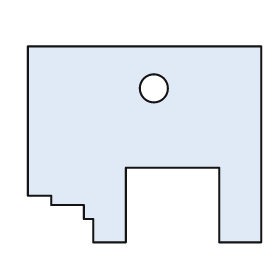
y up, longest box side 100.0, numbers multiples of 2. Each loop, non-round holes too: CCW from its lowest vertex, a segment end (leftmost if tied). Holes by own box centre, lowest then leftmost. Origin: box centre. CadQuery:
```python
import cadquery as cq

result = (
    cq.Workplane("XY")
    .moveTo(-22.0, -42.0)
    .lineTo(-8.0, -42.0)
    .lineTo(-8.0, -10.0)
    .lineTo(32.0, -10.0)
    .lineTo(32.0, -42.0)
    .lineTo(50.0, -42.0)
    .lineTo(50.0, 42.0)
    .lineTo(-50.0, 42.0)
    .lineTo(-50.0, -22.0)
    .lineTo(-40.0, -22.0)
    .lineTo(-40.0, -26.0)
    .lineTo(-26.0, -26.0)
    .lineTo(-26.0, -32.0)
    .lineTo(-22.0, -32.0)
    .close()
    .moveTo(4.0, 24.0)
    .circle(6.0)
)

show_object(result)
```